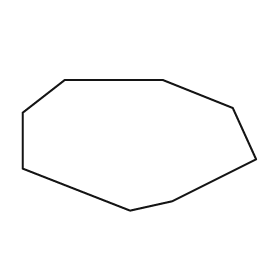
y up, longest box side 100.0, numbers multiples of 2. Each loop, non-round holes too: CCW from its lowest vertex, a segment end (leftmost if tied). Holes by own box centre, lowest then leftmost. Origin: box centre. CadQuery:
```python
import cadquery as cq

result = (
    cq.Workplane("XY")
    .moveTo(-4.0, -28.0)
    .lineTo(14.0, -24.0)
    .lineTo(50.0, -6.0)
    .lineTo(40.0, 16.0)
    .lineTo(10.0, 28.0)
    .lineTo(-32.0, 28.0)
    .lineTo(-50.0, 14.0)
    .lineTo(-50.0, -10.0)
    .close()
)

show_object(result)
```